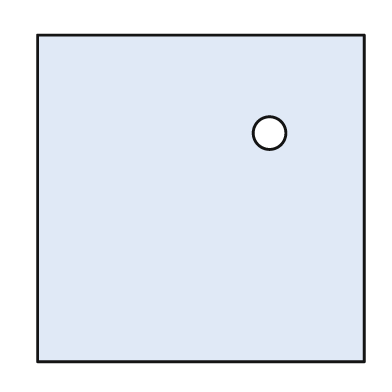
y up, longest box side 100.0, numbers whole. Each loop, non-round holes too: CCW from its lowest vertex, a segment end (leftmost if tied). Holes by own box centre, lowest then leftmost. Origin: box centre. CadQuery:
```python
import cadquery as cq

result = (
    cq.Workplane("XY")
    .moveTo(-50.0, -50.0)
    .lineTo(50.0, -50.0)
    .lineTo(50.0, 50.0)
    .lineTo(-50.0, 50.0)
    .close()
    .moveTo(21.0, 20.0)
    .circle(5.0)
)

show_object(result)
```